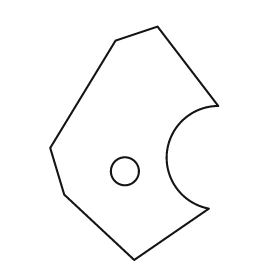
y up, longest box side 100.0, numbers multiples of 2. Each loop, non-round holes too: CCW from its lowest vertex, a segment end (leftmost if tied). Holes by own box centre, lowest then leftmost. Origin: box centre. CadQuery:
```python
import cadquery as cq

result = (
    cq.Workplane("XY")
    .moveTo(0.0, -50.0)
    .lineTo(32.0, -28.0)
    .threePointArc((14.0, -4.0), (36.0, 16.0))
    .lineTo(10.0, 50.0)
    .lineTo(-8.0, 44.0)
    .lineTo(-36.0, -2.0)
    .lineTo(-30.0, -22.0)
    .close()
    .moveTo(-4.0, -12.0)
    .circle(6.0)
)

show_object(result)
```